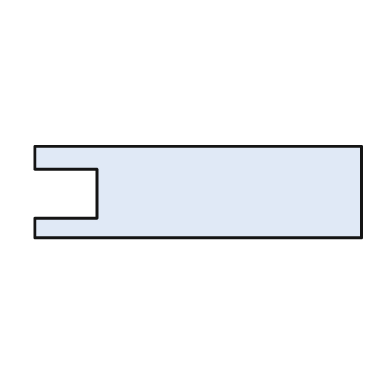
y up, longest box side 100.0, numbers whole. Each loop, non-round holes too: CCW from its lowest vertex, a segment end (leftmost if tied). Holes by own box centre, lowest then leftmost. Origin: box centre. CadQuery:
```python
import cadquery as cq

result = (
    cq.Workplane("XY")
    .moveTo(-50.0, -14.0)
    .lineTo(50.0, -14.0)
    .lineTo(50.0, 14.0)
    .lineTo(-50.0, 14.0)
    .lineTo(-50.0, 7.0)
    .lineTo(-31.0, 7.0)
    .lineTo(-31.0, -8.0)
    .lineTo(-50.0, -8.0)
    .close()
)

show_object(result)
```